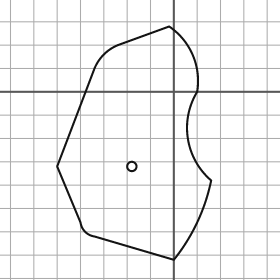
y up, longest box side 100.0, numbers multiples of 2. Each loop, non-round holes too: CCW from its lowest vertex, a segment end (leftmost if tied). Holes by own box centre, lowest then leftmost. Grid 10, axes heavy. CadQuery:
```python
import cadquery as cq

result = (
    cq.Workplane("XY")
    .moveTo(0.0, -72.0)
    .threePointArc((10.0, -56.0), (16.0, -38.0))
    .threePointArc((6.0, -20.0), (10.0, 0.0))
    .threePointArc((8.0, 16.0), (-2.0, 28.0))
    .lineTo(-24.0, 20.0)
    .threePointArc((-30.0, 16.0), (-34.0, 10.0))
    .lineTo(-50.0, -32.0)
    .lineTo(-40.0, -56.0)
    .threePointArc((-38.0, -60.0), (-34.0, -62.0))
    .close()
    .moveTo(-18.0, -32.0)
    .circle(2.0)
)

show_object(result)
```